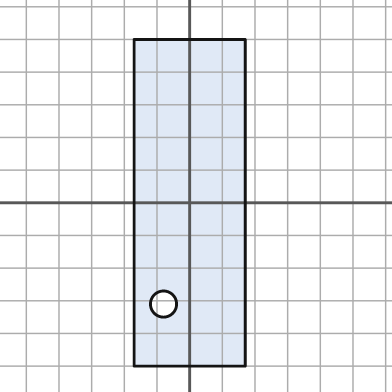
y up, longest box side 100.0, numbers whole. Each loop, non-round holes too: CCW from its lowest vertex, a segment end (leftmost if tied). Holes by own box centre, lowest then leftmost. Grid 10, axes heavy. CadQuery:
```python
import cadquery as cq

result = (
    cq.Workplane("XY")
    .moveTo(-17.0, -50.0)
    .lineTo(17.0, -50.0)
    .lineTo(17.0, 50.0)
    .lineTo(-17.0, 50.0)
    .close()
    .moveTo(-8.0, -31.0)
    .circle(4.0)
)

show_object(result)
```